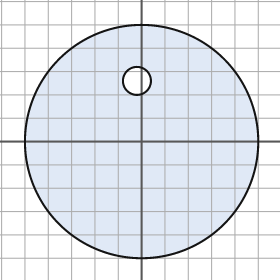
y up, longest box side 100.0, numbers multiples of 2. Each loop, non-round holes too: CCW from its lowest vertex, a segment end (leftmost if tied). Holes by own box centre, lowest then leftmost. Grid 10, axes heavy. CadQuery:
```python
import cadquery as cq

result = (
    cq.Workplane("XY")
    .moveTo(0.0, 0.0)
    .circle(50.0)
    .moveTo(-2.0, 26.0)
    .circle(6.0)
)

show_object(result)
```